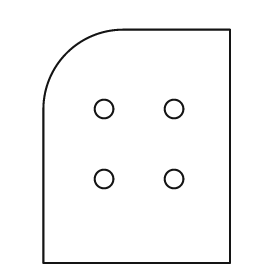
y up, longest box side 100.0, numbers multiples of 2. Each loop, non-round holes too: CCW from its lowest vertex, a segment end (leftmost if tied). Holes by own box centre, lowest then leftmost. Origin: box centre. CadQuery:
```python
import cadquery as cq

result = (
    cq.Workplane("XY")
    .moveTo(-40.0, -50.0)
    .lineTo(40.0, -50.0)
    .lineTo(40.0, 50.0)
    .lineTo(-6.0, 50.0)
    .threePointArc((-30.0, 40.0), (-40.0, 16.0))
    .close()
    .moveTo(-14.0, -14.0)
    .circle(4.0)
    .moveTo(16.0, -14.0)
    .circle(4.0)
    .moveTo(-14.0, 16.0)
    .circle(4.0)
    .moveTo(16.0, 16.0)
    .circle(4.0)
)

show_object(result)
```